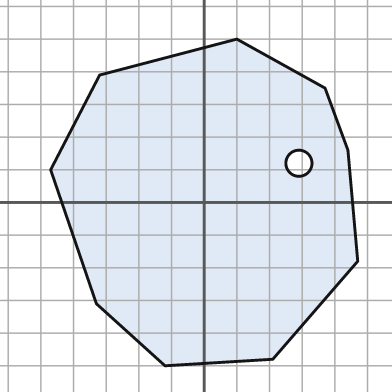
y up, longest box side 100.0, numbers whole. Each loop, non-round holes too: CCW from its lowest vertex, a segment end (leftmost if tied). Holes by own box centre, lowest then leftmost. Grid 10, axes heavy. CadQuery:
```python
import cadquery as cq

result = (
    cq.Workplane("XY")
    .moveTo(-12.0, -50.0)
    .lineTo(21.0, -48.0)
    .lineTo(47.0, -18.0)
    .lineTo(44.0, 16.0)
    .lineTo(37.0, 35.0)
    .lineTo(10.0, 50.0)
    .lineTo(-32.0, 39.0)
    .lineTo(-47.0, 10.0)
    .lineTo(-33.0, -31.0)
    .close()
    .moveTo(29.0, 12.0)
    .circle(4.0)
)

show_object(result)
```